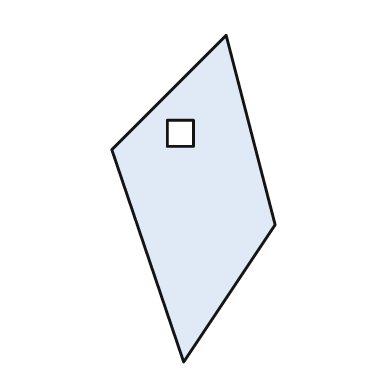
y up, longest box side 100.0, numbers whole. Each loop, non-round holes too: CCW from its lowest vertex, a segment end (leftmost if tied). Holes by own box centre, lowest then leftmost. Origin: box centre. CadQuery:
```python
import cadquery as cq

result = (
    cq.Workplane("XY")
    .moveTo(-3.0, -50.0)
    .lineTo(25.0, -8.0)
    .lineTo(10.0, 50.0)
    .lineTo(-25.0, 15.0)
    .close()
    .moveTo(-8.0, 16.0)
    .lineTo(0.0, 16.0)
    .lineTo(0.0, 24.0)
    .lineTo(-8.0, 24.0)
    .close()
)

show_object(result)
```